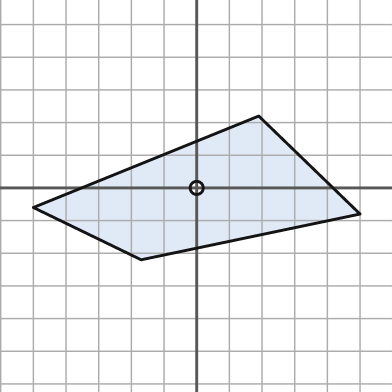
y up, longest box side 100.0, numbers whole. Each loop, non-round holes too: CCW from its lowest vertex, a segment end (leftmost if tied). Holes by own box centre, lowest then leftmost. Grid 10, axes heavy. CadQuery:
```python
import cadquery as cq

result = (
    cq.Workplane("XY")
    .moveTo(-17.0, -22.0)
    .lineTo(50.0, -8.0)
    .lineTo(19.0, 22.0)
    .lineTo(-50.0, -6.0)
    .close()
    .moveTo(0.0, 0.0)
    .circle(2.0)
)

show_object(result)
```